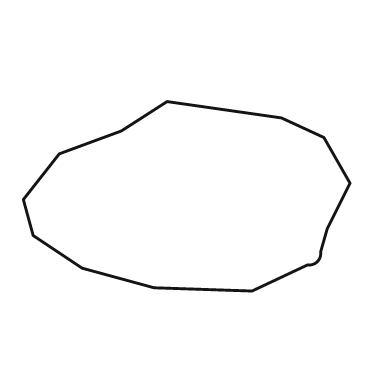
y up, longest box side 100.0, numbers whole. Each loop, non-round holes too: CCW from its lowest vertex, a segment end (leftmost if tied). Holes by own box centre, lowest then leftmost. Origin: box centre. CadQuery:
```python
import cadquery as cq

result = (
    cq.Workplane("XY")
    .moveTo(20.0, -29.0)
    .lineTo(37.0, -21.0)
    .threePointArc((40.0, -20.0), (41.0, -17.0))
    .lineTo(43.0, -10.0)
    .lineTo(50.0, 4.0)
    .lineTo(42.0, 18.0)
    .lineTo(29.0, 24.0)
    .lineTo(-6.0, 29.0)
    .lineTo(-20.0, 20.0)
    .lineTo(-39.0, 13.0)
    .lineTo(-50.0, -1.0)
    .lineTo(-47.0, -12.0)
    .lineTo(-32.0, -22.0)
    .lineTo(-10.0, -28.0)
    .close()
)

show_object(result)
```